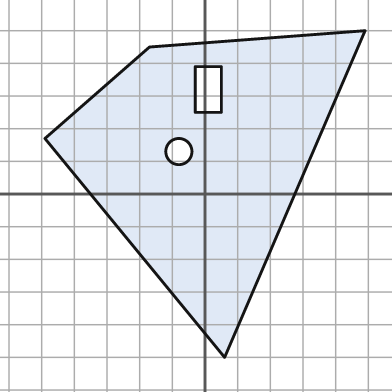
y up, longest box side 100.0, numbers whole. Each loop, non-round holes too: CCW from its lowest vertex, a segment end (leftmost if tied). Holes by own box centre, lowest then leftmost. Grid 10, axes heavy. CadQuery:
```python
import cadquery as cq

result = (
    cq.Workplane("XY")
    .moveTo(6.0, -50.0)
    .lineTo(49.0, 50.0)
    .lineTo(-17.0, 45.0)
    .lineTo(-49.0, 17.0)
    .close()
    .moveTo(-8.0, 13.0)
    .circle(4.0)
    .moveTo(-3.0, 25.0)
    .lineTo(5.0, 25.0)
    .lineTo(5.0, 39.0)
    .lineTo(-3.0, 39.0)
    .close()
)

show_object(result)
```